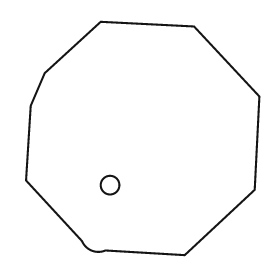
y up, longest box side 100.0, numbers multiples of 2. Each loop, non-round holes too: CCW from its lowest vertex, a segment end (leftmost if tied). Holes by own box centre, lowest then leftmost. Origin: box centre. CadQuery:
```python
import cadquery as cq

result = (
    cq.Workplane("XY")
    .moveTo(18.0, -50.0)
    .lineTo(48.0, -22.0)
    .lineTo(50.0, 18.0)
    .lineTo(22.0, 48.0)
    .lineTo(-18.0, 50.0)
    .lineTo(-42.0, 28.0)
    .lineTo(-48.0, 14.0)
    .lineTo(-50.0, -18.0)
    .lineTo(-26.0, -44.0)
    .threePointArc((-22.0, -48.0), (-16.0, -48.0))
    .close()
    .moveTo(-14.0, -20.0)
    .circle(4.0)
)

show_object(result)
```